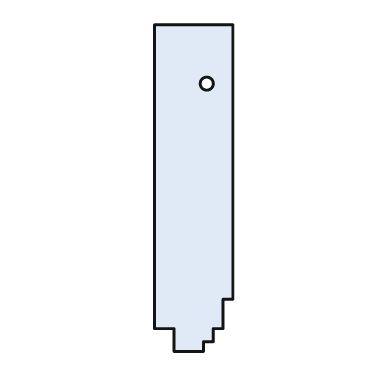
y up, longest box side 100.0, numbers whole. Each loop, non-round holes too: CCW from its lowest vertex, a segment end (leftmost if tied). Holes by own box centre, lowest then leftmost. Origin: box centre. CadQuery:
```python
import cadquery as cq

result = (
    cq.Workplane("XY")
    .moveTo(-6.0, -50.0)
    .lineTo(3.0, -50.0)
    .lineTo(3.0, -47.0)
    .lineTo(6.0, -47.0)
    .lineTo(6.0, -43.0)
    .lineTo(9.0, -43.0)
    .lineTo(9.0, -34.0)
    .lineTo(12.0, -34.0)
    .lineTo(12.0, 50.0)
    .lineTo(-12.0, 50.0)
    .lineTo(-12.0, -43.0)
    .lineTo(-6.0, -43.0)
    .close()
    .moveTo(4.0, 32.0)
    .circle(2.0)
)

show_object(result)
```